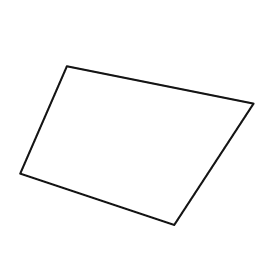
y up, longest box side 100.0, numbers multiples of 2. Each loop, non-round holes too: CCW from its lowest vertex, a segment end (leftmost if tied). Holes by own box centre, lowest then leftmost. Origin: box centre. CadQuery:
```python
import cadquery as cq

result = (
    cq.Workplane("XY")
    .moveTo(16.0, -34.0)
    .lineTo(50.0, 18.0)
    .lineTo(-30.0, 34.0)
    .lineTo(-50.0, -12.0)
    .close()
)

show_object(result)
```